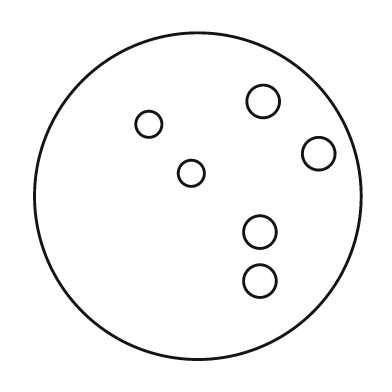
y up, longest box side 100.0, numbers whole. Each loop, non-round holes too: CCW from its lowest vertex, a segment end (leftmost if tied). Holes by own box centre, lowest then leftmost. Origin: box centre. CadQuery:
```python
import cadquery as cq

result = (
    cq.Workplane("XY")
    .moveTo(0.0, 0.0)
    .circle(50.0)
    .moveTo(19.0, -26.0)
    .circle(5.0)
    .moveTo(19.0, -11.0)
    .circle(5.0)
    .moveTo(-2.0, 7.0)
    .circle(4.0)
    .moveTo(37.0, 13.0)
    .circle(5.0)
    .moveTo(-15.0, 22.0)
    .circle(4.0)
    .moveTo(20.0, 29.0)
    .circle(5.0)
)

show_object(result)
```